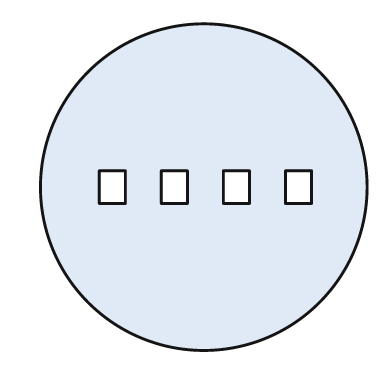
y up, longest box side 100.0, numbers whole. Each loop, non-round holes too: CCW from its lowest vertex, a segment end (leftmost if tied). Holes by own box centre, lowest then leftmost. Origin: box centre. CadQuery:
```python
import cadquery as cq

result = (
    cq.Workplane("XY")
    .moveTo(0.0, 0.0)
    .circle(50.0)
    .moveTo(-32.0, -5.0)
    .lineTo(-24.0, -5.0)
    .lineTo(-24.0, 5.0)
    .lineTo(-32.0, 5.0)
    .close()
    .moveTo(-13.0, -5.0)
    .lineTo(-5.0, -5.0)
    .lineTo(-5.0, 5.0)
    .lineTo(-13.0, 5.0)
    .close()
    .moveTo(6.0, -5.0)
    .lineTo(14.0, -5.0)
    .lineTo(14.0, 5.0)
    .lineTo(6.0, 5.0)
    .close()
    .moveTo(25.0, -5.0)
    .lineTo(33.0, -5.0)
    .lineTo(33.0, 5.0)
    .lineTo(25.0, 5.0)
    .close()
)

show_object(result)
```